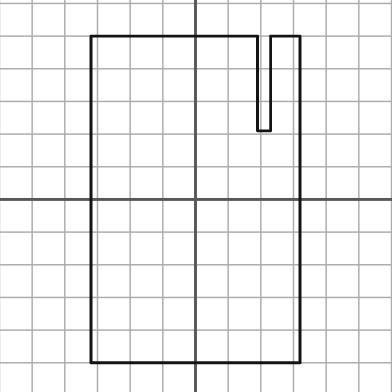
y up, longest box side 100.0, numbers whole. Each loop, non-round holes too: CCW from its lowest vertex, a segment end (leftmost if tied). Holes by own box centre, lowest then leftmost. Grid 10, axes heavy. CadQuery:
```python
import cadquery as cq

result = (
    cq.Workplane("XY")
    .moveTo(-32.0, -50.0)
    .lineTo(32.0, -50.0)
    .lineTo(32.0, 50.0)
    .lineTo(23.0, 50.0)
    .lineTo(23.0, 21.0)
    .lineTo(19.0, 21.0)
    .lineTo(19.0, 50.0)
    .lineTo(-32.0, 50.0)
    .close()
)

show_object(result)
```